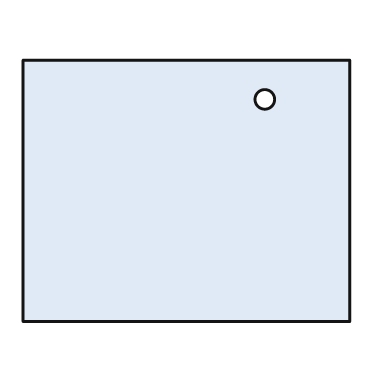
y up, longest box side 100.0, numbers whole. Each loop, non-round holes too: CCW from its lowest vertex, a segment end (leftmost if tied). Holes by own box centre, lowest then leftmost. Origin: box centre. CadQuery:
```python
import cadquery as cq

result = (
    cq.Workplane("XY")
    .moveTo(-50.0, -40.0)
    .lineTo(50.0, -40.0)
    .lineTo(50.0, 40.0)
    .lineTo(-50.0, 40.0)
    .close()
    .moveTo(24.0, 28.0)
    .circle(3.0)
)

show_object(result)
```